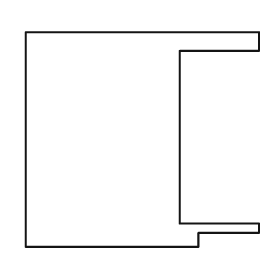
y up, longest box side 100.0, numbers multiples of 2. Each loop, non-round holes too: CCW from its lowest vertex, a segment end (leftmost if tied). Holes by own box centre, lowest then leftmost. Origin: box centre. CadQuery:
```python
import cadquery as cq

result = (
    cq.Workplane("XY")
    .moveTo(-50.0, -46.0)
    .lineTo(24.0, -46.0)
    .lineTo(24.0, -40.0)
    .lineTo(50.0, -40.0)
    .lineTo(50.0, -36.0)
    .lineTo(16.0, -36.0)
    .lineTo(16.0, 38.0)
    .lineTo(50.0, 38.0)
    .lineTo(50.0, 46.0)
    .lineTo(-50.0, 46.0)
    .close()
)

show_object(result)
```